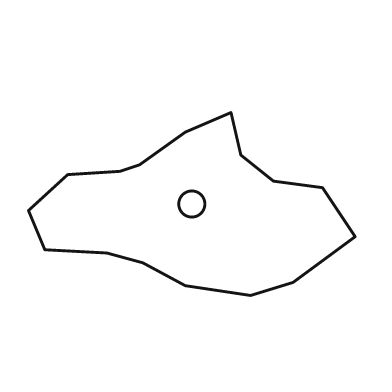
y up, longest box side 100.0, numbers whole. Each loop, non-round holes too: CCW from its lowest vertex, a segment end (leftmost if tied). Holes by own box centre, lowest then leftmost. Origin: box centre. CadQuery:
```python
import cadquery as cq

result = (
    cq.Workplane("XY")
    .moveTo(18.0, -28.0)
    .lineTo(31.0, -24.0)
    .lineTo(50.0, -10.0)
    .lineTo(40.0, 5.0)
    .lineTo(25.0, 7.0)
    .lineTo(15.0, 15.0)
    .lineTo(12.0, 28.0)
    .lineTo(-2.0, 22.0)
    .lineTo(-16.0, 12.0)
    .lineTo(-22.0, 10.0)
    .lineTo(-38.0, 9.0)
    .lineTo(-50.0, -2.0)
    .lineTo(-45.0, -14.0)
    .lineTo(-26.0, -15.0)
    .lineTo(-15.0, -18.0)
    .lineTo(-2.0, -25.0)
    .close()
    .moveTo(0.0, 0.0)
    .circle(4.0)
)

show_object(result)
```